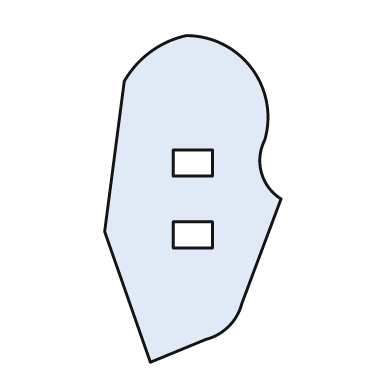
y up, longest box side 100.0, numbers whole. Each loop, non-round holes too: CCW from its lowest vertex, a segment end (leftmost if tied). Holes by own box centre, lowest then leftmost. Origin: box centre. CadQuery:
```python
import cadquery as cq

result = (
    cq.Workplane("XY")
    .moveTo(-13.0, -50.0)
    .lineTo(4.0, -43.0)
    .threePointArc((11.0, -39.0), (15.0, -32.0))
    .lineTo(27.0, 0.0)
    .threePointArc((21.0, 8.0), (22.0, 18.0))
    .threePointArc((18.0, 40.0), (-2.0, 50.0))
    .threePointArc((-13.0, 45.0), (-21.0, 36.0))
    .lineTo(-27.0, -10.0)
    .close()
    .moveTo(-6.0, -15.0)
    .lineTo(6.0, -15.0)
    .lineTo(6.0, -7.0)
    .lineTo(-6.0, -7.0)
    .close()
    .moveTo(-6.0, 7.0)
    .lineTo(6.0, 7.0)
    .lineTo(6.0, 15.0)
    .lineTo(-6.0, 15.0)
    .close()
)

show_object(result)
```